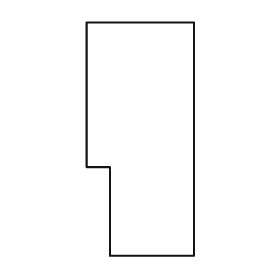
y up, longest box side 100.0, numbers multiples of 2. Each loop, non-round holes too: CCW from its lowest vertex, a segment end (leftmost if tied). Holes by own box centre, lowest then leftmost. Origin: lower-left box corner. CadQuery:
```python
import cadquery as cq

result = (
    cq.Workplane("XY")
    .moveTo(10.0, 0.0)
    .lineTo(46.0, 0.0)
    .lineTo(46.0, 100.0)
    .lineTo(0.0, 100.0)
    .lineTo(0.0, 38.0)
    .lineTo(10.0, 38.0)
    .close()
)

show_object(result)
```